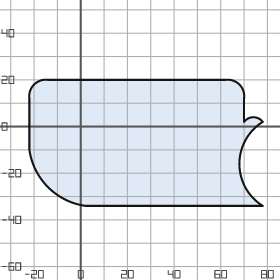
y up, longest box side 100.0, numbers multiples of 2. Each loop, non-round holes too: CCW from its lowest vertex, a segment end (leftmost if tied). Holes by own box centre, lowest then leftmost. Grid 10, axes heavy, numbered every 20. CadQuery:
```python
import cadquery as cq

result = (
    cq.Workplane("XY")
    .moveTo(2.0, -34.0)
    .lineTo(78.0, -34.0)
    .threePointArc((68.0, -16.0), (78.0, 2.0))
    .threePointArc((74.0, 4.0), (70.0, 2.0))
    .lineTo(70.0, 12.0)
    .threePointArc((68.0, 18.0), (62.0, 20.0))
    .lineTo(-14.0, 20.0)
    .threePointArc((-20.0, 18.0), (-22.0, 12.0))
    .lineTo(-22.0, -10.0)
    .threePointArc((-14.0, -26.0), (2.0, -34.0))
    .close()
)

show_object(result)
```